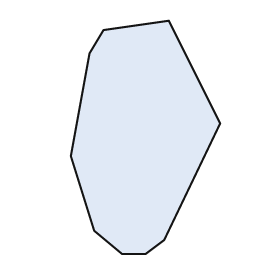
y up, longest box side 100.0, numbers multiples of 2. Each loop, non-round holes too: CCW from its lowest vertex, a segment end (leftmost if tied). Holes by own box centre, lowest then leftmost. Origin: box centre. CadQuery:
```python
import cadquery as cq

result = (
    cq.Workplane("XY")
    .moveTo(-10.0, -50.0)
    .lineTo(0.0, -50.0)
    .lineTo(8.0, -44.0)
    .lineTo(32.0, 6.0)
    .lineTo(10.0, 50.0)
    .lineTo(-18.0, 46.0)
    .lineTo(-24.0, 36.0)
    .lineTo(-32.0, -8.0)
    .lineTo(-22.0, -40.0)
    .close()
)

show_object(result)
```